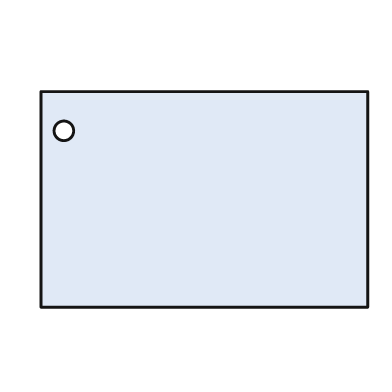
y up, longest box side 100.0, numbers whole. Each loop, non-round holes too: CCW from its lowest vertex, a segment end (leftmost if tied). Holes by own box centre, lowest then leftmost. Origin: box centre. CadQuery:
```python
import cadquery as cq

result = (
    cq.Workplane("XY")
    .moveTo(-50.0, -33.0)
    .lineTo(50.0, -33.0)
    .lineTo(50.0, 33.0)
    .lineTo(-50.0, 33.0)
    .close()
    .moveTo(-43.0, 21.0)
    .circle(3.0)
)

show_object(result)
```